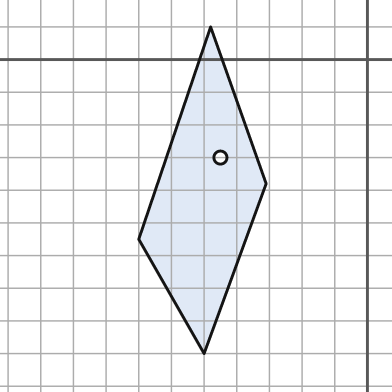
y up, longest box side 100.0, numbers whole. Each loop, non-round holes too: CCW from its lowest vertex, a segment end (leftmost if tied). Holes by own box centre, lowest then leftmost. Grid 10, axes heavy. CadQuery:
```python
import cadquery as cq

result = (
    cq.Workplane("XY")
    .moveTo(-50.0, -90.0)
    .lineTo(-31.0, -38.0)
    .lineTo(-48.0, 10.0)
    .lineTo(-70.0, -55.0)
    .close()
    .moveTo(-45.0, -30.0)
    .circle(2.0)
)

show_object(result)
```